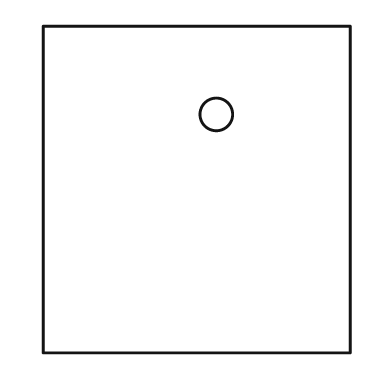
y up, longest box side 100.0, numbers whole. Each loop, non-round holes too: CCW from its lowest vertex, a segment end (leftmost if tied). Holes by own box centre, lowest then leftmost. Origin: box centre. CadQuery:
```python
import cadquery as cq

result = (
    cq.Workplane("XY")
    .moveTo(-47.0, -50.0)
    .lineTo(47.0, -50.0)
    .lineTo(47.0, 50.0)
    .lineTo(-47.0, 50.0)
    .close()
    .moveTo(6.0, 23.0)
    .circle(5.0)
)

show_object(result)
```